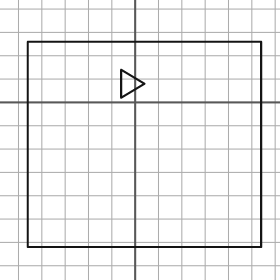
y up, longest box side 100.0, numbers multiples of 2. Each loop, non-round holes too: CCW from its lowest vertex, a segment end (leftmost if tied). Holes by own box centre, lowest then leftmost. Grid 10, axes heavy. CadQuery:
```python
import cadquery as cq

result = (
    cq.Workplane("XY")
    .moveTo(-46.0, -62.0)
    .lineTo(54.0, -62.0)
    .lineTo(54.0, 26.0)
    .lineTo(-46.0, 26.0)
    .close()
    .moveTo(-6.0, 2.0)
    .lineTo(4.0, 8.0)
    .lineTo(-6.0, 14.0)
    .close()
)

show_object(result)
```